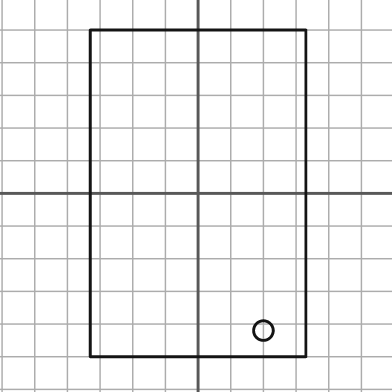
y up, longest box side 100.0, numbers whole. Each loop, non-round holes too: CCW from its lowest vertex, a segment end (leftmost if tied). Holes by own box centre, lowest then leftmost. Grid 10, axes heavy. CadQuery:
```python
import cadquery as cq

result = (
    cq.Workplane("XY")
    .moveTo(-33.0, -50.0)
    .lineTo(33.0, -50.0)
    .lineTo(33.0, 50.0)
    .lineTo(-33.0, 50.0)
    .close()
    .moveTo(20.0, -42.0)
    .circle(3.0)
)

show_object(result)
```